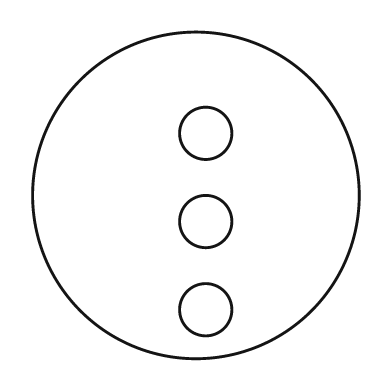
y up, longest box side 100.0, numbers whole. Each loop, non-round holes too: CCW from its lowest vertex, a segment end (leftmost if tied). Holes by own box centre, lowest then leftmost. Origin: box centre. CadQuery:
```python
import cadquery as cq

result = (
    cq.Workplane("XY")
    .moveTo(0.0, 0.0)
    .circle(50.0)
    .moveTo(3.0, -35.0)
    .circle(8.0)
    .moveTo(3.0, -8.0)
    .circle(8.0)
    .moveTo(3.0, 19.0)
    .circle(8.0)
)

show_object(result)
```